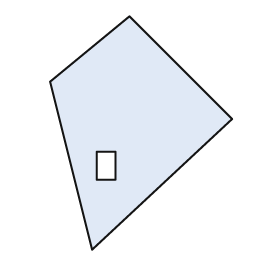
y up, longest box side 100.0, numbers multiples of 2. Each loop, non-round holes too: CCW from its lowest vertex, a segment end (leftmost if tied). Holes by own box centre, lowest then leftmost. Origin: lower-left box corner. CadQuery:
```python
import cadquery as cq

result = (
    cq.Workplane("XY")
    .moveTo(18.0, 0.0)
    .lineTo(78.0, 56.0)
    .lineTo(34.0, 100.0)
    .lineTo(0.0, 72.0)
    .close()
    .moveTo(20.0, 30.0)
    .lineTo(28.0, 30.0)
    .lineTo(28.0, 42.0)
    .lineTo(20.0, 42.0)
    .close()
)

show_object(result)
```